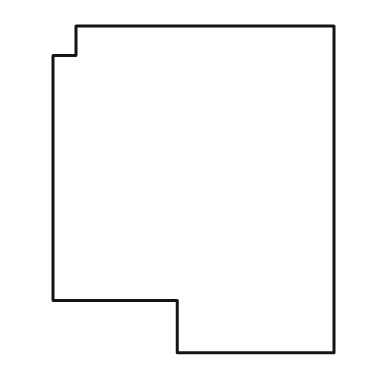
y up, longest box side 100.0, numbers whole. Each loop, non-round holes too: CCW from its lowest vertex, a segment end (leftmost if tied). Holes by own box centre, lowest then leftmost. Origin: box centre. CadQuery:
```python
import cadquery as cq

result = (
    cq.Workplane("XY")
    .moveTo(-5.0, -50.0)
    .lineTo(43.0, -50.0)
    .lineTo(43.0, 50.0)
    .lineTo(-36.0, 50.0)
    .lineTo(-36.0, 41.0)
    .lineTo(-43.0, 41.0)
    .lineTo(-43.0, -34.0)
    .lineTo(-5.0, -34.0)
    .close()
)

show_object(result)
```